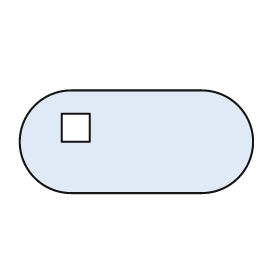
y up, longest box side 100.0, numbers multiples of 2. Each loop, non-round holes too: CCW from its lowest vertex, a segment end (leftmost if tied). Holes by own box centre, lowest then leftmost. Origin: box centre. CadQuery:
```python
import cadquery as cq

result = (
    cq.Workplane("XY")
    .moveTo(-28.0, -22.0)
    .lineTo(28.0, -22.0)
    .threePointArc((50.0, 0.0), (28.0, 22.0))
    .lineTo(-28.0, 22.0)
    .threePointArc((-50.0, 0.0), (-28.0, -22.0))
    .close()
    .moveTo(-32.0, 0.0)
    .lineTo(-20.0, 0.0)
    .lineTo(-20.0, 12.0)
    .lineTo(-32.0, 12.0)
    .close()
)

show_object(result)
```